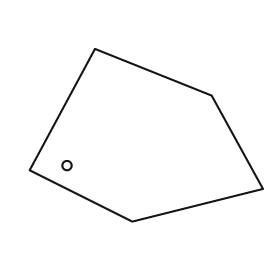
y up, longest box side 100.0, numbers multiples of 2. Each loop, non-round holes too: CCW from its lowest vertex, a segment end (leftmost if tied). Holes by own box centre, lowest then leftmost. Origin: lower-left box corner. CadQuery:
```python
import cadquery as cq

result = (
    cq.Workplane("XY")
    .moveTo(44.0, 0.0)
    .lineTo(100.0, 14.0)
    .lineTo(78.0, 54.0)
    .lineTo(28.0, 74.0)
    .lineTo(0.0, 22.0)
    .close()
    .moveTo(16.0, 24.0)
    .circle(2.0)
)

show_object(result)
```